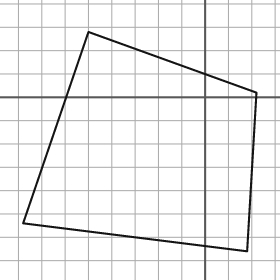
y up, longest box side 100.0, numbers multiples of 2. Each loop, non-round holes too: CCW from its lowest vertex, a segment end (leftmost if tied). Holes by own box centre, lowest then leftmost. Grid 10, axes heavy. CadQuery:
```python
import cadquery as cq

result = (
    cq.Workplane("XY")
    .moveTo(18.0, -66.0)
    .lineTo(22.0, 2.0)
    .lineTo(-50.0, 28.0)
    .lineTo(-78.0, -54.0)
    .close()
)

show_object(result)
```